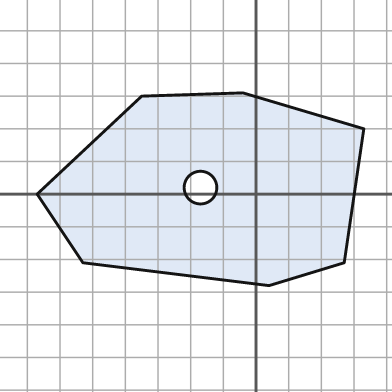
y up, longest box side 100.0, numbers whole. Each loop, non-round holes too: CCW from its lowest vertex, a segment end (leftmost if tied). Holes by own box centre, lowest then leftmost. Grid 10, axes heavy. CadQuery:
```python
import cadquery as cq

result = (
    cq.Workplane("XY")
    .moveTo(4.0, -28.0)
    .lineTo(27.0, -21.0)
    .lineTo(33.0, 20.0)
    .lineTo(-4.0, 31.0)
    .lineTo(-35.0, 30.0)
    .lineTo(-67.0, 0.0)
    .lineTo(-53.0, -21.0)
    .close()
    .moveTo(-17.0, 2.0)
    .circle(5.0)
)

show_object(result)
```